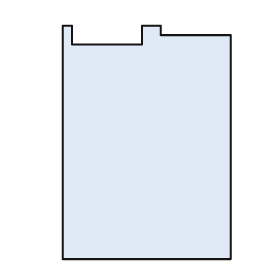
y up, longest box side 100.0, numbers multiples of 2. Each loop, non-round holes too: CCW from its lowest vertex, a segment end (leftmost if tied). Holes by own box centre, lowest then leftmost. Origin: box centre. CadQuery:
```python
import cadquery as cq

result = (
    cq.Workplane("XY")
    .moveTo(-36.0, -50.0)
    .lineTo(36.0, -50.0)
    .lineTo(36.0, 46.0)
    .lineTo(6.0, 46.0)
    .lineTo(6.0, 50.0)
    .lineTo(-2.0, 50.0)
    .lineTo(-2.0, 42.0)
    .lineTo(-32.0, 42.0)
    .lineTo(-32.0, 50.0)
    .lineTo(-36.0, 50.0)
    .close()
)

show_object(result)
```